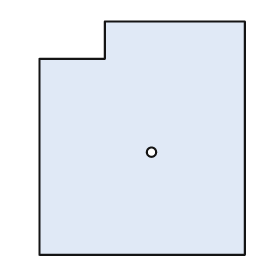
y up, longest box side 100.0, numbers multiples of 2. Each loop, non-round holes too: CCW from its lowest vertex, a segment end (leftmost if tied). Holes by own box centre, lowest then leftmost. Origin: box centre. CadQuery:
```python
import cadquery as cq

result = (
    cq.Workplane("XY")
    .moveTo(-44.0, -50.0)
    .lineTo(44.0, -50.0)
    .lineTo(44.0, 50.0)
    .lineTo(-16.0, 50.0)
    .lineTo(-16.0, 34.0)
    .lineTo(-44.0, 34.0)
    .close()
    .moveTo(4.0, -6.0)
    .circle(2.0)
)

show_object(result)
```